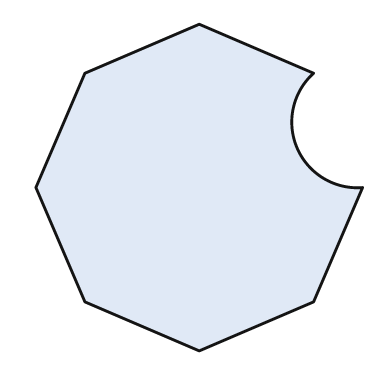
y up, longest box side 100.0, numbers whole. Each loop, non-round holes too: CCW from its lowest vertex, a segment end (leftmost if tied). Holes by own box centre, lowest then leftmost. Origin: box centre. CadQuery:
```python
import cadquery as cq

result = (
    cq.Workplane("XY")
    .moveTo(0.0, -50.0)
    .lineTo(35.0, -35.0)
    .lineTo(50.0, 0.0)
    .threePointArc((30.0, 12.0), (35.0, 35.0))
    .lineTo(0.0, 50.0)
    .lineTo(-35.0, 35.0)
    .lineTo(-50.0, 0.0)
    .lineTo(-35.0, -35.0)
    .close()
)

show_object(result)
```